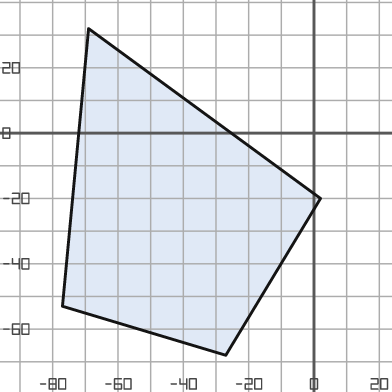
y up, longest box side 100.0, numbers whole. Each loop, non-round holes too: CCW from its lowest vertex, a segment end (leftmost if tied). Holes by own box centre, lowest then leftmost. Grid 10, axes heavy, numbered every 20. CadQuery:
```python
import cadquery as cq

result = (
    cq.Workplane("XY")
    .moveTo(-27.0, -68.0)
    .lineTo(2.0, -20.0)
    .lineTo(-69.0, 32.0)
    .lineTo(-77.0, -53.0)
    .close()
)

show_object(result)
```